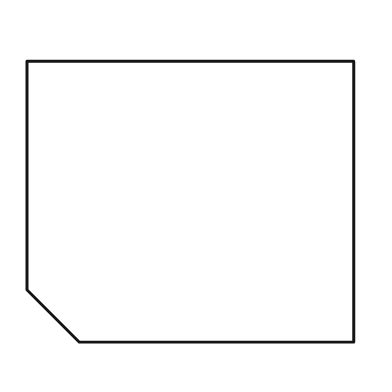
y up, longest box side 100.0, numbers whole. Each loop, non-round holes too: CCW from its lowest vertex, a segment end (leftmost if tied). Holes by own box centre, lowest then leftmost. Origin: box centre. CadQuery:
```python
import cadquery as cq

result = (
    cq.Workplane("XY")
    .moveTo(-34.0, -43.0)
    .lineTo(50.0, -43.0)
    .lineTo(50.0, 43.0)
    .lineTo(-50.0, 43.0)
    .lineTo(-50.0, -27.0)
    .close()
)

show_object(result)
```